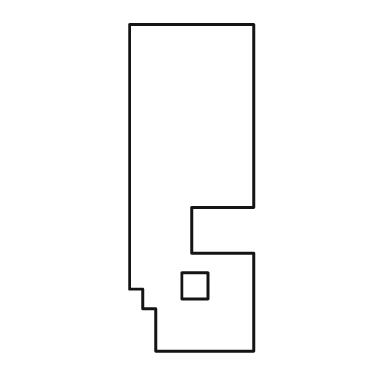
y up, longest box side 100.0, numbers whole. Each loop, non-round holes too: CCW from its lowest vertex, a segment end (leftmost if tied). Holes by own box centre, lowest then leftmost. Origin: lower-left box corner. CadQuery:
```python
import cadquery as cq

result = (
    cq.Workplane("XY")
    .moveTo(8.0, 0.0)
    .lineTo(38.0, 0.0)
    .lineTo(38.0, 30.0)
    .lineTo(19.0, 30.0)
    .lineTo(19.0, 44.0)
    .lineTo(38.0, 44.0)
    .lineTo(38.0, 100.0)
    .lineTo(0.0, 100.0)
    .lineTo(0.0, 19.0)
    .lineTo(4.0, 19.0)
    .lineTo(4.0, 13.0)
    .lineTo(8.0, 13.0)
    .close()
    .moveTo(16.0, 16.0)
    .lineTo(24.0, 16.0)
    .lineTo(24.0, 24.0)
    .lineTo(16.0, 24.0)
    .close()
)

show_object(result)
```